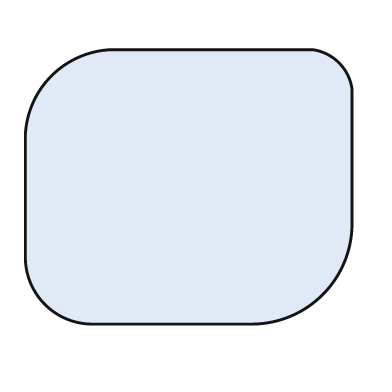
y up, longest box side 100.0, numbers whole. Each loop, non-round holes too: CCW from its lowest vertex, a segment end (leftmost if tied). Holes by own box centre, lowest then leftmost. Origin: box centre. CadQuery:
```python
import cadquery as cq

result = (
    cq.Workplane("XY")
    .moveTo(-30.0, -42.0)
    .lineTo(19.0, -42.0)
    .threePointArc((41.0, -33.0), (50.0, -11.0))
    .lineTo(50.0, 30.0)
    .threePointArc((46.0, 38.0), (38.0, 42.0))
    .lineTo(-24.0, 42.0)
    .threePointArc((-42.0, 34.0), (-50.0, 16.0))
    .lineTo(-50.0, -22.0)
    .threePointArc((-44.0, -36.0), (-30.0, -42.0))
    .close()
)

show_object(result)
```